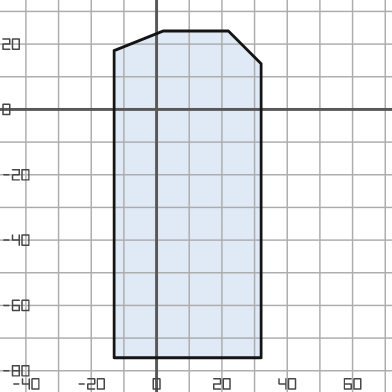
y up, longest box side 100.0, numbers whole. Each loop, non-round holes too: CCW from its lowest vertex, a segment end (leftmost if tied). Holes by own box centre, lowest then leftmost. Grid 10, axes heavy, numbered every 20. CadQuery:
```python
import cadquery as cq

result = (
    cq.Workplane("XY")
    .moveTo(-13.0, -76.0)
    .lineTo(32.0, -76.0)
    .lineTo(32.0, 14.0)
    .lineTo(22.0, 24.0)
    .lineTo(2.0, 24.0)
    .lineTo(-13.0, 18.0)
    .close()
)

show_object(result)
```